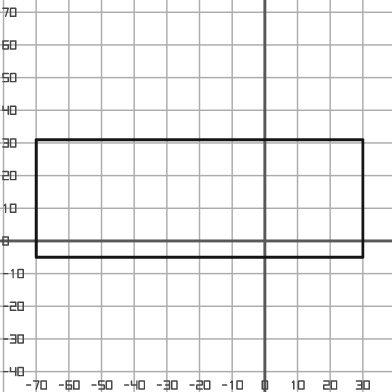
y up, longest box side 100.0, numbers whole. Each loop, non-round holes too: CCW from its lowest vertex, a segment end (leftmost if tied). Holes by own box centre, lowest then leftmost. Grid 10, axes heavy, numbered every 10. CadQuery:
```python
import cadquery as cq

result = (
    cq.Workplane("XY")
    .moveTo(-70.0, -5.0)
    .lineTo(30.0, -5.0)
    .lineTo(30.0, 31.0)
    .lineTo(-70.0, 31.0)
    .close()
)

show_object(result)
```